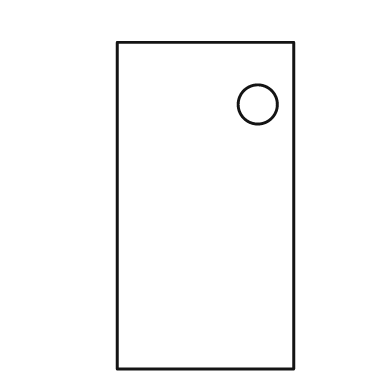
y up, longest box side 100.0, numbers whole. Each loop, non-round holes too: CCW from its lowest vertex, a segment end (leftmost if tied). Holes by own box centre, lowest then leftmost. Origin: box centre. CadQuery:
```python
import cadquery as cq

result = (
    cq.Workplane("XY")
    .moveTo(-27.0, -50.0)
    .lineTo(27.0, -50.0)
    .lineTo(27.0, 50.0)
    .lineTo(-27.0, 50.0)
    .close()
    .moveTo(16.0, 31.0)
    .circle(6.0)
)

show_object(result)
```